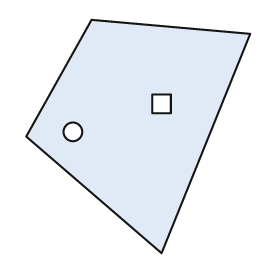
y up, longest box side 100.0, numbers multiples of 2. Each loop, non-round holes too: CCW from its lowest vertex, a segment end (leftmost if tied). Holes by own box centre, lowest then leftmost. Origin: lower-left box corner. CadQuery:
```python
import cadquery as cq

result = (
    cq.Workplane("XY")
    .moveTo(58.0, 0.0)
    .lineTo(96.0, 94.0)
    .lineTo(28.0, 100.0)
    .lineTo(0.0, 50.0)
    .close()
    .moveTo(20.0, 52.0)
    .circle(4.0)
    .moveTo(54.0, 60.0)
    .lineTo(62.0, 60.0)
    .lineTo(62.0, 68.0)
    .lineTo(54.0, 68.0)
    .close()
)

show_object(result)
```